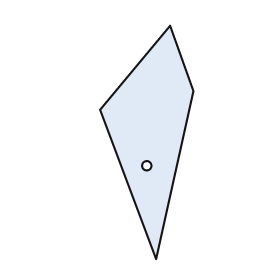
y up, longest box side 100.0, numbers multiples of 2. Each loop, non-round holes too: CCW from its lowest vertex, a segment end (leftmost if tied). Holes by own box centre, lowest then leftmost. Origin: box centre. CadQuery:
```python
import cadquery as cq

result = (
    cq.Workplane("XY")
    .moveTo(4.0, -50.0)
    .lineTo(20.0, 22.0)
    .lineTo(10.0, 50.0)
    .lineTo(-20.0, 14.0)
    .close()
    .moveTo(0.0, -10.0)
    .circle(2.0)
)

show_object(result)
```